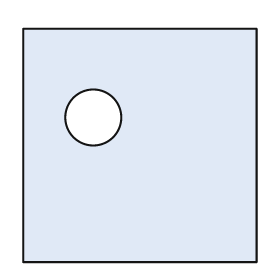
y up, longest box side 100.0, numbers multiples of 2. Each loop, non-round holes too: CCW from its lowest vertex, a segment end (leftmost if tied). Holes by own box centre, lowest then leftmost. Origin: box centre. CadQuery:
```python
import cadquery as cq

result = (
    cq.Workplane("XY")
    .moveTo(-50.0, -50.0)
    .lineTo(50.0, -50.0)
    .lineTo(50.0, 50.0)
    .lineTo(-50.0, 50.0)
    .close()
    .moveTo(-20.0, 12.0)
    .circle(12.0)
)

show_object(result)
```